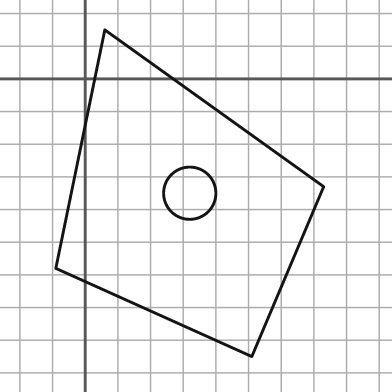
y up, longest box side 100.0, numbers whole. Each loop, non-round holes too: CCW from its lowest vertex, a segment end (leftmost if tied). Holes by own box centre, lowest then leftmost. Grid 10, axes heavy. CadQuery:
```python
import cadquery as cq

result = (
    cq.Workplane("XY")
    .moveTo(51.0, -85.0)
    .lineTo(73.0, -33.0)
    .lineTo(6.0, 15.0)
    .lineTo(-9.0, -58.0)
    .close()
    .moveTo(32.0, -35.0)
    .circle(8.0)
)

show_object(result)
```